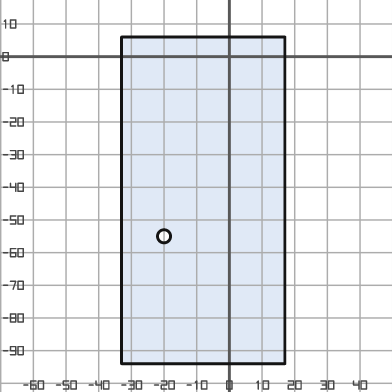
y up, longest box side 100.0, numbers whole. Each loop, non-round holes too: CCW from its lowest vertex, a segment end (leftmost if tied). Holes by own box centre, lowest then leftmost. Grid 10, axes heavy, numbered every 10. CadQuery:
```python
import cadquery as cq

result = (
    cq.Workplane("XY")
    .moveTo(-33.0, -94.0)
    .lineTo(17.0, -94.0)
    .lineTo(17.0, 6.0)
    .lineTo(-33.0, 6.0)
    .close()
    .moveTo(-20.0, -55.0)
    .circle(2.0)
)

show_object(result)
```